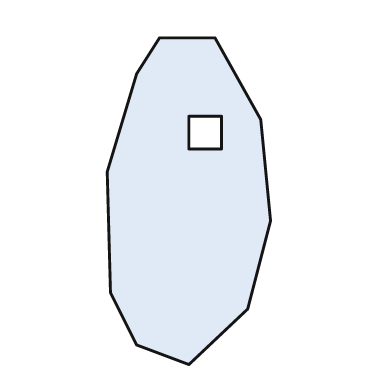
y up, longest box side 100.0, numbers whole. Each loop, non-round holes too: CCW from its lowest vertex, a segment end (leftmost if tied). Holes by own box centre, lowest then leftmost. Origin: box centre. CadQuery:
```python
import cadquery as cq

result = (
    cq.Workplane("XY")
    .moveTo(0.0, -50.0)
    .lineTo(18.0, -33.0)
    .lineTo(25.0, -6.0)
    .lineTo(22.0, 25.0)
    .lineTo(8.0, 50.0)
    .lineTo(-9.0, 50.0)
    .lineTo(-16.0, 39.0)
    .lineTo(-25.0, 9.0)
    .lineTo(-24.0, -28.0)
    .lineTo(-16.0, -44.0)
    .close()
    .moveTo(0.0, 16.0)
    .lineTo(10.0, 16.0)
    .lineTo(10.0, 26.0)
    .lineTo(0.0, 26.0)
    .close()
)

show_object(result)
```